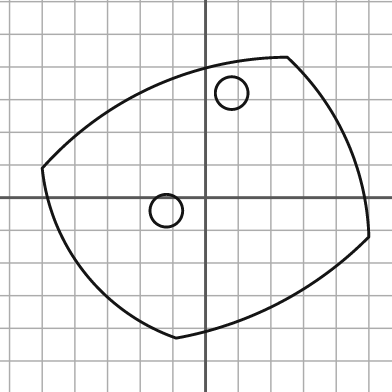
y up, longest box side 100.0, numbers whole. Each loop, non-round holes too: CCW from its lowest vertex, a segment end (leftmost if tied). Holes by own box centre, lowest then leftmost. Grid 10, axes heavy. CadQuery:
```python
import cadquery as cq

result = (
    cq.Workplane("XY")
    .moveTo(-9.0, -43.0)
    .threePointArc((23.0, -32.0), (50.0, -12.0))
    .threePointArc((43.0, 18.0), (25.0, 43.0))
    .threePointArc((-16.0, 34.0), (-50.0, 9.0))
    .threePointArc((-37.0, -23.0), (-9.0, -43.0))
    .close()
    .moveTo(-12.0, -4.0)
    .circle(5.0)
    .moveTo(8.0, 32.0)
    .circle(5.0)
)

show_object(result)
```